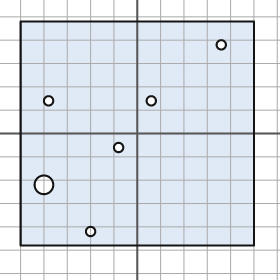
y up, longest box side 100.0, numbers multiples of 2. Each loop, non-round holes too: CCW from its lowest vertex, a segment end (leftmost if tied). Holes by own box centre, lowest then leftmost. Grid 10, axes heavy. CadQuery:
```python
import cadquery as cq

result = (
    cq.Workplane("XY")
    .moveTo(-50.0, -48.0)
    .lineTo(50.0, -48.0)
    .lineTo(50.0, 48.0)
    .lineTo(-50.0, 48.0)
    .close()
    .moveTo(-20.0, -42.0)
    .circle(2.0)
    .moveTo(-40.0, -22.0)
    .circle(4.0)
    .moveTo(-8.0, -6.0)
    .circle(2.0)
    .moveTo(-38.0, 14.0)
    .circle(2.0)
    .moveTo(6.0, 14.0)
    .circle(2.0)
    .moveTo(36.0, 38.0)
    .circle(2.0)
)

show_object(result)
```